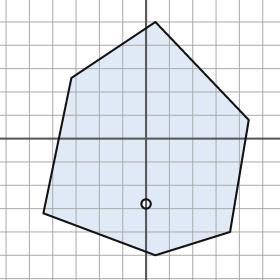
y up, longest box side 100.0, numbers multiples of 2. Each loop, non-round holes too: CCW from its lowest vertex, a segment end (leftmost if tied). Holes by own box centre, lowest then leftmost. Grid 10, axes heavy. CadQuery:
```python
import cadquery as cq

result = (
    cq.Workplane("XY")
    .moveTo(4.0, -50.0)
    .lineTo(36.0, -40.0)
    .lineTo(44.0, 8.0)
    .lineTo(4.0, 50.0)
    .lineTo(-32.0, 26.0)
    .lineTo(-44.0, -32.0)
    .close()
    .moveTo(0.0, -28.0)
    .circle(2.0)
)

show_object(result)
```